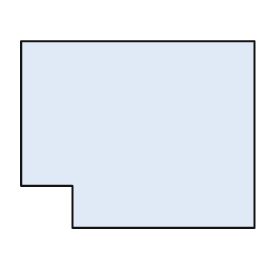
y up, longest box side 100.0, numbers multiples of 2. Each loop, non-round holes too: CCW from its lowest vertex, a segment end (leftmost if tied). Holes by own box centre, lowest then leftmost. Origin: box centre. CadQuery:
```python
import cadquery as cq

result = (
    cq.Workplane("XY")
    .moveTo(-28.0, -40.0)
    .lineTo(50.0, -40.0)
    .lineTo(50.0, 40.0)
    .lineTo(-50.0, 40.0)
    .lineTo(-50.0, -22.0)
    .lineTo(-28.0, -22.0)
    .close()
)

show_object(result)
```